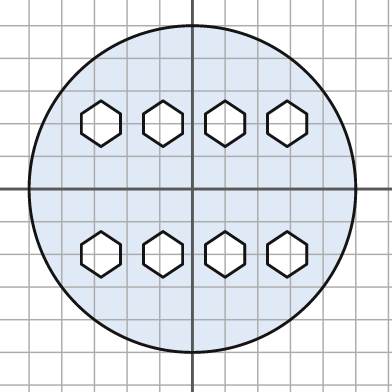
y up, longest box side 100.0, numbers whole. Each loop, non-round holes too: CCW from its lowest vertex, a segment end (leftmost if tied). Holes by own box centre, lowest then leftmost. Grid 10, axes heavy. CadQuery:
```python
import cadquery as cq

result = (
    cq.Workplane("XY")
    .moveTo(0.0, 0.0)
    .circle(50.0)
    .moveTo(-28.0, -27.0)
    .lineTo(-22.0, -23.0)
    .lineTo(-22.0, -17.0)
    .lineTo(-28.0, -13.0)
    .lineTo(-34.0, -17.0)
    .lineTo(-34.0, -23.0)
    .close()
    .moveTo(-9.0, -27.0)
    .lineTo(-3.0, -23.0)
    .lineTo(-3.0, -17.0)
    .lineTo(-9.0, -13.0)
    .lineTo(-15.0, -17.0)
    .lineTo(-15.0, -23.0)
    .close()
    .moveTo(10.0, -27.0)
    .lineTo(16.0, -23.0)
    .lineTo(16.0, -17.0)
    .lineTo(10.0, -13.0)
    .lineTo(4.0, -17.0)
    .lineTo(4.0, -23.0)
    .close()
    .moveTo(29.0, -27.0)
    .lineTo(35.0, -23.0)
    .lineTo(35.0, -17.0)
    .lineTo(29.0, -13.0)
    .lineTo(23.0, -17.0)
    .lineTo(23.0, -23.0)
    .close()
    .moveTo(-28.0, 13.0)
    .lineTo(-22.0, 17.0)
    .lineTo(-22.0, 23.0)
    .lineTo(-28.0, 27.0)
    .lineTo(-34.0, 23.0)
    .lineTo(-34.0, 17.0)
    .close()
    .moveTo(-9.0, 13.0)
    .lineTo(-3.0, 17.0)
    .lineTo(-3.0, 23.0)
    .lineTo(-9.0, 27.0)
    .lineTo(-15.0, 23.0)
    .lineTo(-15.0, 17.0)
    .close()
    .moveTo(10.0, 13.0)
    .lineTo(16.0, 17.0)
    .lineTo(16.0, 23.0)
    .lineTo(10.0, 27.0)
    .lineTo(4.0, 23.0)
    .lineTo(4.0, 17.0)
    .close()
    .moveTo(29.0, 13.0)
    .lineTo(35.0, 17.0)
    .lineTo(35.0, 23.0)
    .lineTo(29.0, 27.0)
    .lineTo(23.0, 23.0)
    .lineTo(23.0, 17.0)
    .close()
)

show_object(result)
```